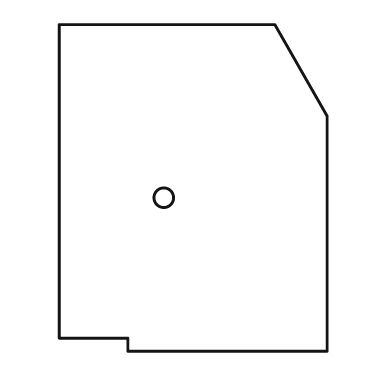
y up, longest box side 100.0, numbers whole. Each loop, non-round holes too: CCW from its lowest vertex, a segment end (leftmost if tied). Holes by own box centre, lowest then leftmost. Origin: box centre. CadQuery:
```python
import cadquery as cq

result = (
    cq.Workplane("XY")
    .moveTo(-20.0, -50.0)
    .lineTo(41.0, -50.0)
    .lineTo(41.0, 22.0)
    .lineTo(25.0, 50.0)
    .lineTo(-41.0, 50.0)
    .lineTo(-41.0, -46.0)
    .lineTo(-20.0, -46.0)
    .close()
    .moveTo(-9.0, -3.0)
    .circle(3.0)
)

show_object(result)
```